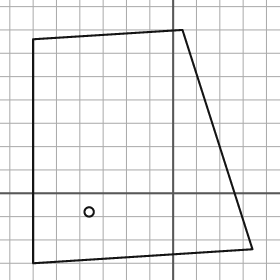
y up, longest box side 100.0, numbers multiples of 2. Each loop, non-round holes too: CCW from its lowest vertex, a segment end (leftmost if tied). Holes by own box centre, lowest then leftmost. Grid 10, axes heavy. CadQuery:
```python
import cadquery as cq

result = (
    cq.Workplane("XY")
    .moveTo(-60.0, -30.0)
    .lineTo(34.0, -24.0)
    .lineTo(4.0, 70.0)
    .lineTo(-60.0, 66.0)
    .close()
    .moveTo(-36.0, -8.0)
    .circle(2.0)
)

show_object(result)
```